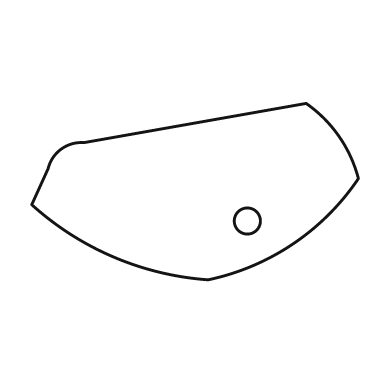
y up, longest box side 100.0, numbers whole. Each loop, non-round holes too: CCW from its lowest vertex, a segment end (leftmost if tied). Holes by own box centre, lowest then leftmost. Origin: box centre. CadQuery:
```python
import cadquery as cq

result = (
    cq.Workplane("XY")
    .moveTo(4.0, -27.0)
    .threePointArc((30.0, -16.0), (50.0, 4.0))
    .threePointArc((44.0, 17.0), (34.0, 27.0))
    .lineTo(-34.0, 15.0)
    .threePointArc((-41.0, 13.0), (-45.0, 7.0))
    .lineTo(-50.0, -4.0)
    .threePointArc((-25.0, -20.0), (4.0, -27.0))
    .close()
    .moveTo(16.0, -9.0)
    .circle(4.0)
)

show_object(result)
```